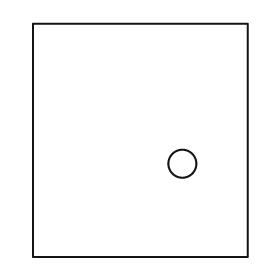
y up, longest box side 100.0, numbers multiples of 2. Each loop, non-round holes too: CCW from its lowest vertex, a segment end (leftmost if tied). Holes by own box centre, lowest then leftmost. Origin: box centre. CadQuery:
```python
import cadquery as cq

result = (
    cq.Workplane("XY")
    .moveTo(-46.0, -50.0)
    .lineTo(46.0, -50.0)
    .lineTo(46.0, 50.0)
    .lineTo(-46.0, 50.0)
    .close()
    .moveTo(18.0, -10.0)
    .circle(6.0)
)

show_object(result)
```